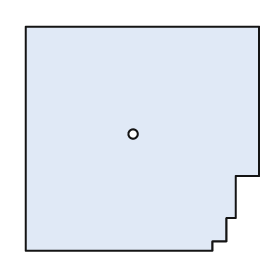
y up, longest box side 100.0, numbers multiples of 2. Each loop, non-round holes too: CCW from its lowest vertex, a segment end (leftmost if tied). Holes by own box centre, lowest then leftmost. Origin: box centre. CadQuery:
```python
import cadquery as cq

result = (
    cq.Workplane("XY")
    .moveTo(-50.0, -48.0)
    .lineTo(30.0, -48.0)
    .lineTo(30.0, -44.0)
    .lineTo(36.0, -44.0)
    .lineTo(36.0, -34.0)
    .lineTo(40.0, -34.0)
    .lineTo(40.0, -16.0)
    .lineTo(50.0, -16.0)
    .lineTo(50.0, 48.0)
    .lineTo(-50.0, 48.0)
    .close()
    .moveTo(-4.0, 2.0)
    .circle(2.0)
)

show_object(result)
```